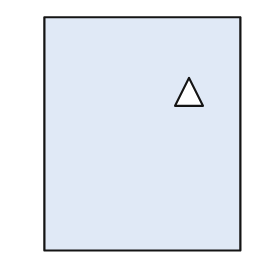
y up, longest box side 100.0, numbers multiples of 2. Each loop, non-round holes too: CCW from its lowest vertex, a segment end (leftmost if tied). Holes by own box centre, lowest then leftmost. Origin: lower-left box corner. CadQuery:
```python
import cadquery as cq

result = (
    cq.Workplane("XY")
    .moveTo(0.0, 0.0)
    .lineTo(84.0, 0.0)
    .lineTo(84.0, 100.0)
    .lineTo(0.0, 100.0)
    .close()
    .moveTo(56.0, 62.0)
    .lineTo(68.0, 62.0)
    .lineTo(62.0, 74.0)
    .close()
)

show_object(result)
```